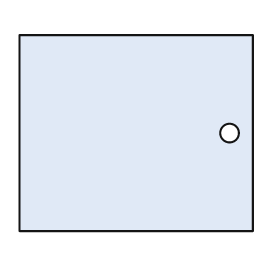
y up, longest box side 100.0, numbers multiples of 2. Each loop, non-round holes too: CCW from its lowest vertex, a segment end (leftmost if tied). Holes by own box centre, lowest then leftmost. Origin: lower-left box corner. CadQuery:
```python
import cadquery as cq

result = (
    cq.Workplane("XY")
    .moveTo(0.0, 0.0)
    .lineTo(100.0, 0.0)
    .lineTo(100.0, 84.0)
    .lineTo(0.0, 84.0)
    .close()
    .moveTo(90.0, 42.0)
    .circle(4.0)
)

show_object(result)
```